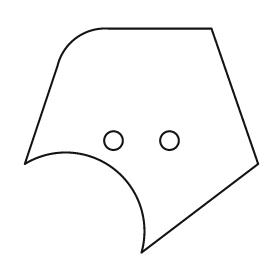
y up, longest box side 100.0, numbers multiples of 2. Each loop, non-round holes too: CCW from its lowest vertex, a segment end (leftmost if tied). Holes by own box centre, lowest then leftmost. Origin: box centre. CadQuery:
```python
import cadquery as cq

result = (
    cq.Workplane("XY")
    .moveTo(0.0, -48.0)
    .lineTo(50.0, -10.0)
    .lineTo(30.0, 48.0)
    .lineTo(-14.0, 48.0)
    .threePointArc((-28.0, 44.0), (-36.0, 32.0))
    .lineTo(-50.0, -10.0)
    .threePointArc((-12.0, -12.0), (0.0, -48.0))
    .close()
    .moveTo(-12.0, 0.0)
    .circle(4.0)
    .moveTo(12.0, 0.0)
    .circle(4.0)
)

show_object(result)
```